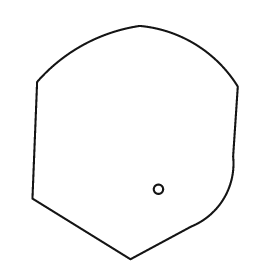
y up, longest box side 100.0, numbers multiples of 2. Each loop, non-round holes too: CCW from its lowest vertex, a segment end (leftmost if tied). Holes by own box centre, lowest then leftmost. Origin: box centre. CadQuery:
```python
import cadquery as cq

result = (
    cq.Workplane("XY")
    .moveTo(-2.0, -50.0)
    .lineTo(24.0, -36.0)
    .threePointArc((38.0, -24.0), (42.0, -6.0))
    .lineTo(44.0, 24.0)
    .threePointArc((26.0, 42.0), (2.0, 50.0))
    .threePointArc((-22.0, 42.0), (-42.0, 26.0))
    .lineTo(-44.0, -24.0)
    .close()
    .moveTo(10.0, -20.0)
    .circle(2.0)
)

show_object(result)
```